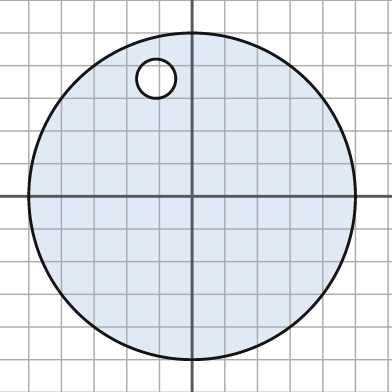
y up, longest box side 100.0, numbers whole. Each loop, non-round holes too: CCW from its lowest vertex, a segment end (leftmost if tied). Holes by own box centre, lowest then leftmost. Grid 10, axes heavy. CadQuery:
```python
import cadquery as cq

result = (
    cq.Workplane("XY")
    .moveTo(0.0, 0.0)
    .circle(50.0)
    .moveTo(-11.0, 36.0)
    .circle(6.0)
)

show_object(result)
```